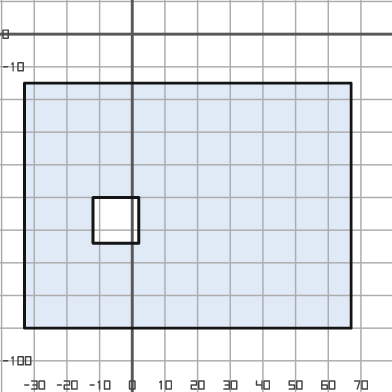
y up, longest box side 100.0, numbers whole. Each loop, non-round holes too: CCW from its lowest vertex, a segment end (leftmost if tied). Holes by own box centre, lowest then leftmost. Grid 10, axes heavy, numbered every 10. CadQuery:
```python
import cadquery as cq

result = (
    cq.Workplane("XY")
    .moveTo(-33.0, -90.0)
    .lineTo(67.0, -90.0)
    .lineTo(67.0, -15.0)
    .lineTo(-33.0, -15.0)
    .close()
    .moveTo(-12.0, -64.0)
    .lineTo(2.0, -64.0)
    .lineTo(2.0, -50.0)
    .lineTo(-12.0, -50.0)
    .close()
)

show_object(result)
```